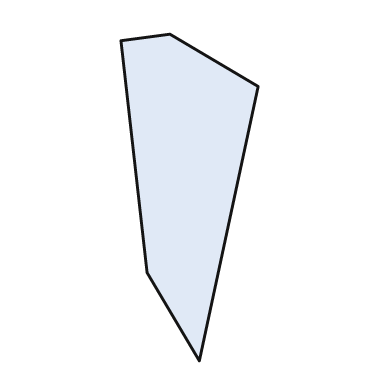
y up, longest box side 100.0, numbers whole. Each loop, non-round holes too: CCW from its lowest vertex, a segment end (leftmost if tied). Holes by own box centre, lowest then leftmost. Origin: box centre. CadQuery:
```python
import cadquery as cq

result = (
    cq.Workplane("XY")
    .moveTo(3.0, -50.0)
    .lineTo(21.0, 34.0)
    .lineTo(-6.0, 50.0)
    .lineTo(-21.0, 48.0)
    .lineTo(-13.0, -23.0)
    .close()
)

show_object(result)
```